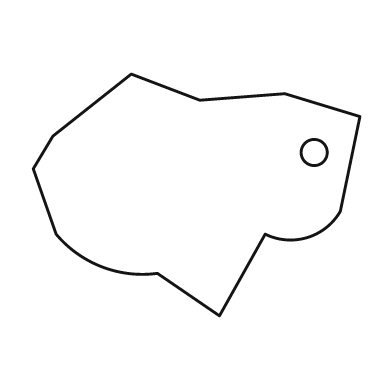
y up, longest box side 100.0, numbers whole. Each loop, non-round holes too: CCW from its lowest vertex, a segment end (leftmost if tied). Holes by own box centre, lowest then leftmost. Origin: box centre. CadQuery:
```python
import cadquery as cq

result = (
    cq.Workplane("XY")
    .moveTo(7.0, -37.0)
    .lineTo(21.0, -12.0)
    .threePointArc((34.0, -13.0), (44.0, -5.0))
    .lineTo(50.0, 24.0)
    .lineTo(27.0, 31.0)
    .lineTo(1.0, 29.0)
    .lineTo(-20.0, 37.0)
    .lineTo(-44.0, 18.0)
    .lineTo(-50.0, 8.0)
    .lineTo(-43.0, -12.0)
    .threePointArc((-29.0, -22.0), (-12.0, -24.0))
    .close()
    .moveTo(36.0, 13.0)
    .circle(4.0)
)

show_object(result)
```